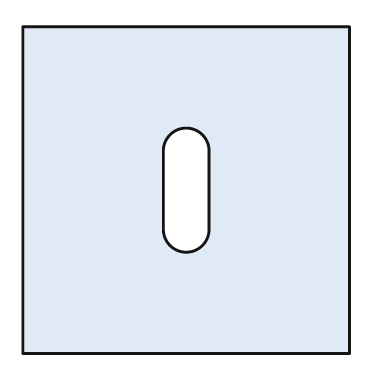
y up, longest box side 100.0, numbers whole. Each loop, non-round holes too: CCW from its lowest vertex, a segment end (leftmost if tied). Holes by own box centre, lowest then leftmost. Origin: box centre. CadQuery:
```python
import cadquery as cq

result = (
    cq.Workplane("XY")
    .moveTo(-50.0, -50.0)
    .lineTo(50.0, -50.0)
    .lineTo(50.0, 50.0)
    .lineTo(-50.0, 50.0)
    .close()
    .moveTo(-7.0, -12.0)
    .threePointArc((0.0, -19.0), (7.0, -12.0))
    .lineTo(7.0, 12.0)
    .threePointArc((0.0, 19.0), (-7.0, 12.0))
    .close()
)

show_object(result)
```